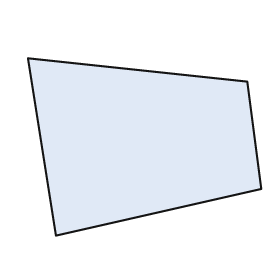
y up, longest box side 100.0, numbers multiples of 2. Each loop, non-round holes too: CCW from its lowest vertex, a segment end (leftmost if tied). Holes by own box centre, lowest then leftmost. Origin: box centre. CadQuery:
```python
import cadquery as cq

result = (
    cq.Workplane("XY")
    .moveTo(-38.0, -38.0)
    .lineTo(50.0, -18.0)
    .lineTo(44.0, 28.0)
    .lineTo(-50.0, 38.0)
    .close()
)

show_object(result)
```